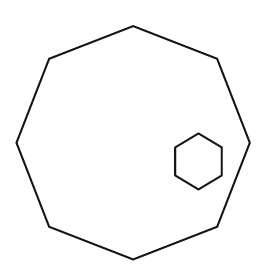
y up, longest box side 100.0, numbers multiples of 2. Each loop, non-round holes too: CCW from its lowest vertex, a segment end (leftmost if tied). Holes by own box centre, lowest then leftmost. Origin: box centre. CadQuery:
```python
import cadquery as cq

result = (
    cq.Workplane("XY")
    .moveTo(0.0, -50.0)
    .lineTo(36.0, -36.0)
    .lineTo(50.0, 0.0)
    .lineTo(36.0, 36.0)
    .lineTo(0.0, 50.0)
    .lineTo(-36.0, 36.0)
    .lineTo(-50.0, 0.0)
    .lineTo(-36.0, -36.0)
    .close()
    .moveTo(28.0, -20.0)
    .lineTo(38.0, -14.0)
    .lineTo(38.0, -2.0)
    .lineTo(28.0, 4.0)
    .lineTo(18.0, -2.0)
    .lineTo(18.0, -14.0)
    .close()
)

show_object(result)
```